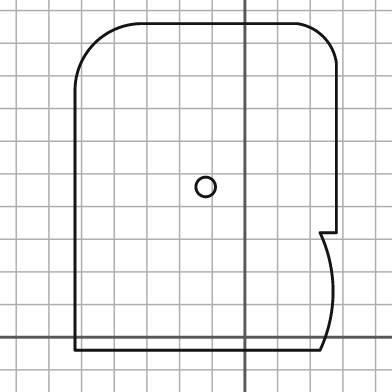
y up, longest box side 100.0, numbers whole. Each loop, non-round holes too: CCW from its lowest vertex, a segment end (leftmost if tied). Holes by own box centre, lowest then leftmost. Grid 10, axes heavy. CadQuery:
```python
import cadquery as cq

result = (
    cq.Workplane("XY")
    .moveTo(-52.0, -4.0)
    .lineTo(23.0, -4.0)
    .threePointArc((27.0, 14.0), (23.0, 32.0))
    .lineTo(28.0, 32.0)
    .lineTo(28.0, 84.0)
    .threePointArc((24.0, 92.0), (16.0, 96.0))
    .lineTo(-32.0, 96.0)
    .threePointArc((-46.0, 90.0), (-52.0, 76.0))
    .close()
    .moveTo(-12.0, 46.0)
    .circle(3.0)
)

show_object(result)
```